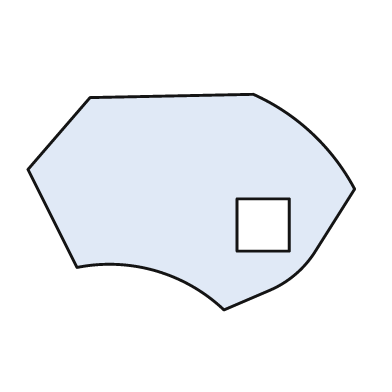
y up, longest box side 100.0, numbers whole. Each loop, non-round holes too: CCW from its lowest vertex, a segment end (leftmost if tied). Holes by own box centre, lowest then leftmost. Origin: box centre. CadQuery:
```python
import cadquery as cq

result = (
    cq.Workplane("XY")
    .moveTo(10.0, -33.0)
    .lineTo(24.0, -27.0)
    .threePointArc((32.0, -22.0), (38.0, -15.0))
    .lineTo(50.0, 4.0)
    .threePointArc((37.0, 21.0), (19.0, 33.0))
    .lineTo(-31.0, 32.0)
    .lineTo(-50.0, 10.0)
    .lineTo(-35.0, -20.0)
    .threePointArc((-11.0, -21.0), (10.0, -33.0))
    .close()
    .moveTo(14.0, -15.0)
    .lineTo(30.0, -15.0)
    .lineTo(30.0, 1.0)
    .lineTo(14.0, 1.0)
    .close()
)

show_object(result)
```